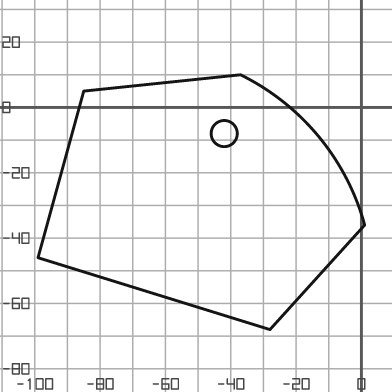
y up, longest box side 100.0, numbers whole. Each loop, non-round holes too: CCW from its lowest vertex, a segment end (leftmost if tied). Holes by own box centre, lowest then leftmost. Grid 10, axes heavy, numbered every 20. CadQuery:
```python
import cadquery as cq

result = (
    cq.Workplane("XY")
    .moveTo(-28.0, -68.0)
    .lineTo(1.0, -36.0)
    .threePointArc((-13.0, -9.0), (-37.0, 10.0))
    .lineTo(-85.0, 5.0)
    .lineTo(-99.0, -46.0)
    .close()
    .moveTo(-42.0, -8.0)
    .circle(4.0)
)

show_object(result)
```